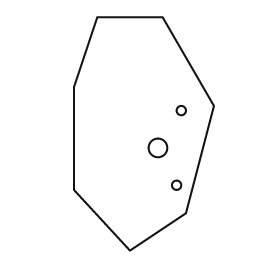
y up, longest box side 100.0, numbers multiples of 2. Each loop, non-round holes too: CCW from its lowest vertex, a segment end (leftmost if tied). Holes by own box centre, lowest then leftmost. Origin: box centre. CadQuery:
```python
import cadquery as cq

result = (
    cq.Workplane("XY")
    .moveTo(-6.0, -50.0)
    .lineTo(18.0, -34.0)
    .lineTo(30.0, 12.0)
    .lineTo(8.0, 50.0)
    .lineTo(-20.0, 50.0)
    .lineTo(-30.0, 20.0)
    .lineTo(-30.0, -24.0)
    .close()
    .moveTo(14.0, -22.0)
    .circle(2.0)
    .moveTo(6.0, -6.0)
    .circle(4.0)
    .moveTo(16.0, 10.0)
    .circle(2.0)
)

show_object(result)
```